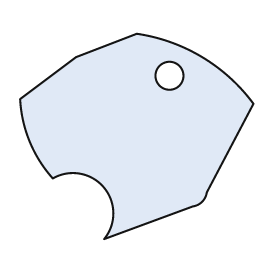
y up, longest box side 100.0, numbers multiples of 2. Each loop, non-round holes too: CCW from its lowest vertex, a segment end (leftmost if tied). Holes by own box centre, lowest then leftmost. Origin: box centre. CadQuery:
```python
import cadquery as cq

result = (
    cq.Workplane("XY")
    .moveTo(-14.0, -44.0)
    .lineTo(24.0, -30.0)
    .threePointArc((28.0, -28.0), (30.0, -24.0))
    .lineTo(50.0, 14.0)
    .threePointArc((28.0, 34.0), (0.0, 44.0))
    .lineTo(-26.0, 34.0)
    .lineTo(-50.0, 16.0)
    .threePointArc((-46.0, -2.0), (-36.0, -18.0))
    .threePointArc((-14.0, -22.0), (-14.0, -44.0))
    .close()
    .moveTo(14.0, 26.0)
    .circle(6.0)
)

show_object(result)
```